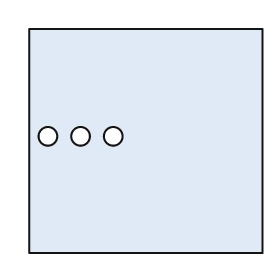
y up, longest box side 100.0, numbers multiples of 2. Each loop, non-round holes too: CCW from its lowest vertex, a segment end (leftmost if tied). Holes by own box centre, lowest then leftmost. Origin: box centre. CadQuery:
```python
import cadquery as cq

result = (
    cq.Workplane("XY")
    .moveTo(-50.0, -48.0)
    .lineTo(50.0, -48.0)
    .lineTo(50.0, 48.0)
    .lineTo(-50.0, 48.0)
    .close()
    .moveTo(-42.0, 2.0)
    .circle(4.0)
    .moveTo(-28.0, 2.0)
    .circle(4.0)
    .moveTo(-14.0, 2.0)
    .circle(4.0)
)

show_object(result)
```